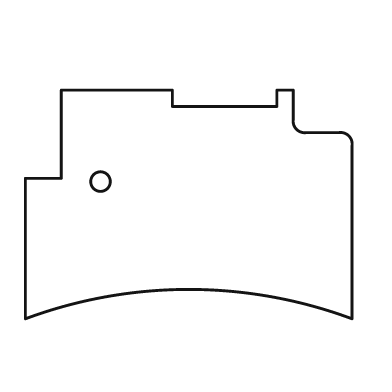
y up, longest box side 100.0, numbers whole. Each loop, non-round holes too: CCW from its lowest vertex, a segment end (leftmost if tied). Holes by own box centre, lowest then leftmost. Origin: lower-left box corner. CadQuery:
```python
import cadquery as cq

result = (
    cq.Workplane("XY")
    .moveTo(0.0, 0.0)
    .threePointArc((50.0, 9.0), (100.0, 0.0))
    .lineTo(100.0, 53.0)
    .threePointArc((99.0, 56.0), (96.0, 57.0))
    .lineTo(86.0, 57.0)
    .threePointArc((83.0, 58.0), (82.0, 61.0))
    .lineTo(82.0, 70.0)
    .lineTo(77.0, 70.0)
    .lineTo(77.0, 65.0)
    .lineTo(45.0, 65.0)
    .lineTo(45.0, 70.0)
    .lineTo(11.0, 70.0)
    .lineTo(11.0, 43.0)
    .lineTo(0.0, 43.0)
    .close()
    .moveTo(23.0, 42.0)
    .circle(3.0)
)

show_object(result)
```